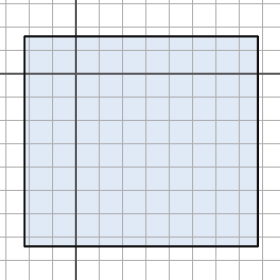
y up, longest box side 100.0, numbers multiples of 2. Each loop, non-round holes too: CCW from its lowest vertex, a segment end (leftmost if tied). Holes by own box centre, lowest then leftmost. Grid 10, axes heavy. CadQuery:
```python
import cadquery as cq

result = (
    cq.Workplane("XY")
    .moveTo(-22.0, -74.0)
    .lineTo(78.0, -74.0)
    .lineTo(78.0, 16.0)
    .lineTo(-22.0, 16.0)
    .close()
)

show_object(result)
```